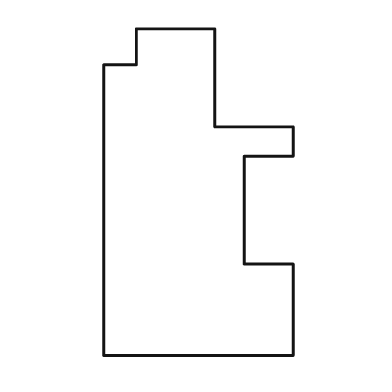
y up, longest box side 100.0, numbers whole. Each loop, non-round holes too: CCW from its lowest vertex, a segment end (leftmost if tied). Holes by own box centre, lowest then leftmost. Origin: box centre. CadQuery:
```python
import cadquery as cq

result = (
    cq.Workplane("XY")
    .moveTo(-29.0, -50.0)
    .lineTo(29.0, -50.0)
    .lineTo(29.0, -22.0)
    .lineTo(14.0, -22.0)
    .lineTo(14.0, 11.0)
    .lineTo(29.0, 11.0)
    .lineTo(29.0, 20.0)
    .lineTo(5.0, 20.0)
    .lineTo(5.0, 50.0)
    .lineTo(-19.0, 50.0)
    .lineTo(-19.0, 39.0)
    .lineTo(-29.0, 39.0)
    .close()
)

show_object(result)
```